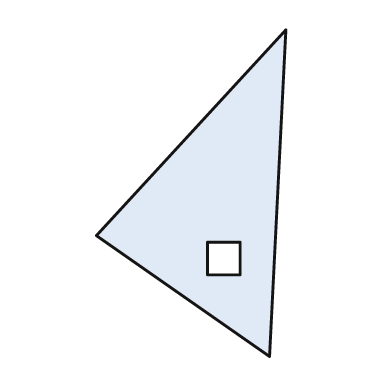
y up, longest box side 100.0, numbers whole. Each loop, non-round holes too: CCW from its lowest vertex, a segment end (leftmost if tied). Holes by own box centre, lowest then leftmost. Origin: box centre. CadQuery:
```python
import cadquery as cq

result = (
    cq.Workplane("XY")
    .moveTo(24.0, -50.0)
    .lineTo(29.0, 50.0)
    .lineTo(-29.0, -13.0)
    .close()
    .moveTo(5.0, -25.0)
    .lineTo(15.0, -25.0)
    .lineTo(15.0, -15.0)
    .lineTo(5.0, -15.0)
    .close()
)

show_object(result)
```